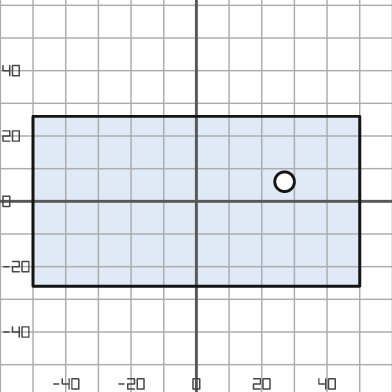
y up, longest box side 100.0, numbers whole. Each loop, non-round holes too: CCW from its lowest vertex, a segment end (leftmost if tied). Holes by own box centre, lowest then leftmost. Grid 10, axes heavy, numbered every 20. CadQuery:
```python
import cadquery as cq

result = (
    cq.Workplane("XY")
    .moveTo(-50.0, -26.0)
    .lineTo(50.0, -26.0)
    .lineTo(50.0, 26.0)
    .lineTo(-50.0, 26.0)
    .close()
    .moveTo(27.0, 6.0)
    .circle(3.0)
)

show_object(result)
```